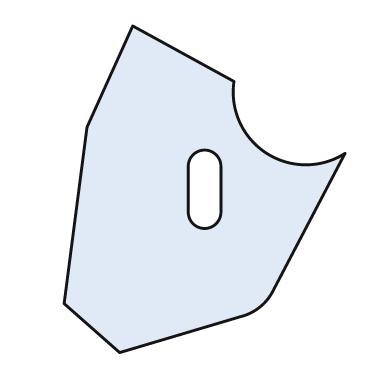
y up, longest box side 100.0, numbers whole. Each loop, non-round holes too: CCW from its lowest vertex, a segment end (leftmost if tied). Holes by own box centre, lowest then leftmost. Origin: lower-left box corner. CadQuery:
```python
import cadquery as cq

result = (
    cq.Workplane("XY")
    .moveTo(17.0, 0.0)
    .lineTo(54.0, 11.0)
    .threePointArc((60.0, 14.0), (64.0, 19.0))
    .lineTo(86.0, 61.0)
    .threePointArc((62.0, 61.0), (52.0, 83.0))
    .lineTo(21.0, 100.0)
    .lineTo(7.0, 69.0)
    .lineTo(0.0, 15.0)
    .close()
    .moveTo(38.0, 43.0)
    .threePointArc((43.0, 38.0), (48.0, 43.0))
    .lineTo(48.0, 57.0)
    .threePointArc((43.0, 62.0), (38.0, 57.0))
    .close()
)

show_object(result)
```